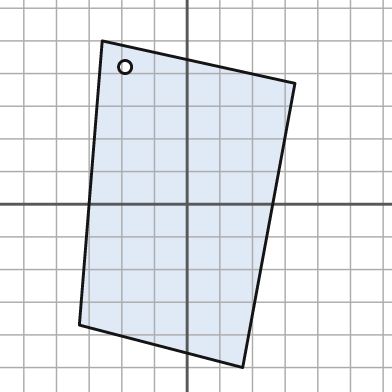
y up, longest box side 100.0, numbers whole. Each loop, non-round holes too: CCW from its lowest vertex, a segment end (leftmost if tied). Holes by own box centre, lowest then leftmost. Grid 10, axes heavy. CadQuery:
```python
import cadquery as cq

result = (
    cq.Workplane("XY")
    .moveTo(17.0, -50.0)
    .lineTo(33.0, 37.0)
    .lineTo(-26.0, 50.0)
    .lineTo(-33.0, -37.0)
    .close()
    .moveTo(-19.0, 42.0)
    .circle(2.0)
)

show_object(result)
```